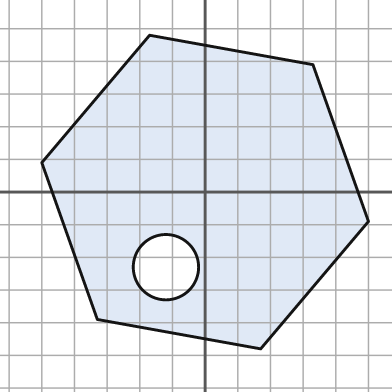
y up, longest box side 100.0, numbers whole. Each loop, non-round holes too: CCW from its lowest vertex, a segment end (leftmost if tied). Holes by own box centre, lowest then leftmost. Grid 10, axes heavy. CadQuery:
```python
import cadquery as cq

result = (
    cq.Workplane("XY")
    .moveTo(17.0, -48.0)
    .lineTo(50.0, -9.0)
    .lineTo(33.0, 39.0)
    .lineTo(-17.0, 48.0)
    .lineTo(-50.0, 9.0)
    .lineTo(-33.0, -39.0)
    .close()
    .moveTo(-12.0, -23.0)
    .circle(10.0)
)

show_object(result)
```